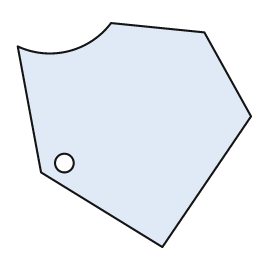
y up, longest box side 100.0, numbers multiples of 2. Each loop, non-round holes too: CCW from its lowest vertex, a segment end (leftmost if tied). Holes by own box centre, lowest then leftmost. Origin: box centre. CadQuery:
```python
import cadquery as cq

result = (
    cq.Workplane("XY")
    .moveTo(12.0, -48.0)
    .lineTo(50.0, 8.0)
    .lineTo(30.0, 44.0)
    .lineTo(-10.0, 48.0)
    .threePointArc((-28.0, 36.0), (-50.0, 38.0))
    .lineTo(-40.0, -16.0)
    .close()
    .moveTo(-30.0, -12.0)
    .circle(4.0)
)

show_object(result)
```